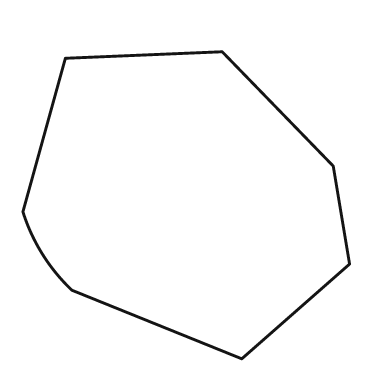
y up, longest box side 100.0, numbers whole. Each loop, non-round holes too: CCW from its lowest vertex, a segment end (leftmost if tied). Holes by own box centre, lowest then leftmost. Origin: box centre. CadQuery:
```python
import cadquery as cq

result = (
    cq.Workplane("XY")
    .moveTo(17.0, -47.0)
    .lineTo(50.0, -18.0)
    .lineTo(45.0, 12.0)
    .lineTo(11.0, 47.0)
    .lineTo(-37.0, 45.0)
    .lineTo(-50.0, -2.0)
    .threePointArc((-44.0, -15.0), (-35.0, -26.0))
    .close()
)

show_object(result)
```